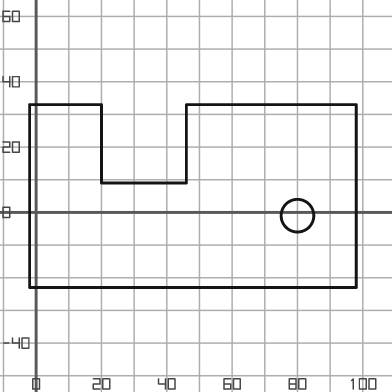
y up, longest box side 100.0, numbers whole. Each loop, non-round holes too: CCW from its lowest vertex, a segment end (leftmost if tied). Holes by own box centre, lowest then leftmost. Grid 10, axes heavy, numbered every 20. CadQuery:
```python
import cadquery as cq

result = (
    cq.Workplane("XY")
    .moveTo(-2.0, -23.0)
    .lineTo(98.0, -23.0)
    .lineTo(98.0, 33.0)
    .lineTo(46.0, 33.0)
    .lineTo(46.0, 9.0)
    .lineTo(20.0, 9.0)
    .lineTo(20.0, 33.0)
    .lineTo(-2.0, 33.0)
    .close()
    .moveTo(80.0, -1.0)
    .circle(5.0)
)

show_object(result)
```